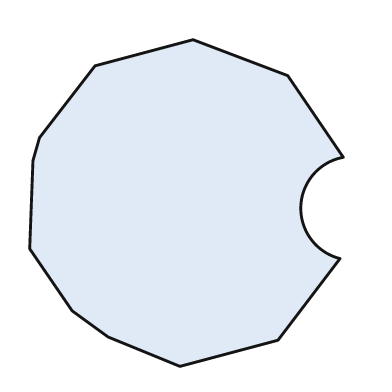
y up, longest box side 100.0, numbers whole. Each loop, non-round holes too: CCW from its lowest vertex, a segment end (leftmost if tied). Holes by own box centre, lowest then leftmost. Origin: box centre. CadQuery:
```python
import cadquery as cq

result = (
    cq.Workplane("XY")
    .moveTo(-2.0, -50.0)
    .lineTo(28.0, -42.0)
    .lineTo(47.0, -17.0)
    .threePointArc((35.0, -1.0), (48.0, 14.0))
    .lineTo(31.0, 39.0)
    .lineTo(2.0, 50.0)
    .lineTo(-28.0, 42.0)
    .lineTo(-45.0, 20.0)
    .lineTo(-47.0, 13.0)
    .lineTo(-48.0, -14.0)
    .lineTo(-35.0, -33.0)
    .lineTo(-24.0, -41.0)
    .close()
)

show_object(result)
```